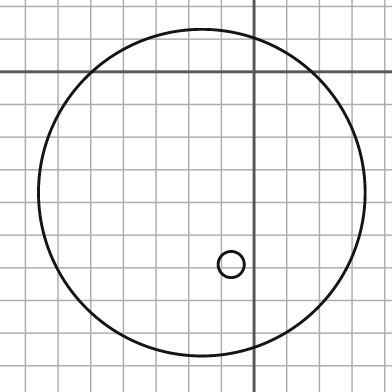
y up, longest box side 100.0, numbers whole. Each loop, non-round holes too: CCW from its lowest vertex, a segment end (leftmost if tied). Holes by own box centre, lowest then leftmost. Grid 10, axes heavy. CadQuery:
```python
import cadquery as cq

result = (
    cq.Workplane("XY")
    .moveTo(-16.0, -37.0)
    .circle(50.0)
    .moveTo(-7.0, -59.0)
    .circle(4.0)
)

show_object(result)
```